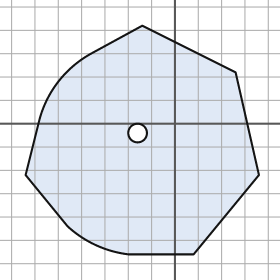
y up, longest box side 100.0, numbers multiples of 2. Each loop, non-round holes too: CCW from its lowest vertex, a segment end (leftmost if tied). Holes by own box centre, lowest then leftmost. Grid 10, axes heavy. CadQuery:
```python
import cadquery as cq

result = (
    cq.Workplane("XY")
    .moveTo(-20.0, -56.0)
    .lineTo(8.0, -56.0)
    .lineTo(36.0, -22.0)
    .lineTo(26.0, 22.0)
    .lineTo(-14.0, 42.0)
    .lineTo(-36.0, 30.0)
    .threePointArc((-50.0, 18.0), (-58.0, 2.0))
    .lineTo(-64.0, -22.0)
    .lineTo(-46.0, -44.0)
    .threePointArc((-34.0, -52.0), (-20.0, -56.0))
    .close()
    .moveTo(-16.0, -4.0)
    .circle(4.0)
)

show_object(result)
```